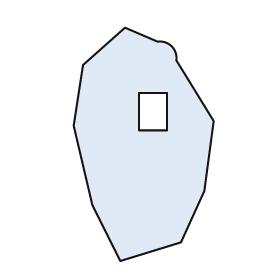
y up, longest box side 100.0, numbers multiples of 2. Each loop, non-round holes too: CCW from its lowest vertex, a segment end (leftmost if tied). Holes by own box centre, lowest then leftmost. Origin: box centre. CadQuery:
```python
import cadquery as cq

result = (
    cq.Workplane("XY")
    .moveTo(-10.0, -50.0)
    .lineTo(16.0, -42.0)
    .lineTo(26.0, -20.0)
    .lineTo(30.0, 10.0)
    .lineTo(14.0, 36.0)
    .threePointArc((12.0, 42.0), (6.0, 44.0))
    .lineTo(-8.0, 50.0)
    .lineTo(-26.0, 34.0)
    .lineTo(-30.0, 8.0)
    .lineTo(-22.0, -26.0)
    .close()
    .moveTo(-2.0, 6.0)
    .lineTo(10.0, 6.0)
    .lineTo(10.0, 22.0)
    .lineTo(-2.0, 22.0)
    .close()
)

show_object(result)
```